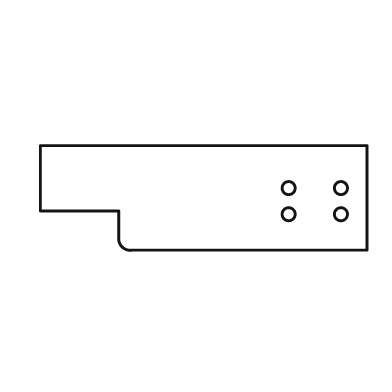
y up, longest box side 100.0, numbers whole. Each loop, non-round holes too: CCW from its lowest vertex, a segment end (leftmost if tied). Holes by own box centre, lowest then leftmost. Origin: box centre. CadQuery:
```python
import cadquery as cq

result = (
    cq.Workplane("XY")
    .moveTo(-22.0, -16.0)
    .lineTo(50.0, -16.0)
    .lineTo(50.0, 16.0)
    .lineTo(-50.0, 16.0)
    .lineTo(-50.0, -4.0)
    .lineTo(-26.0, -4.0)
    .lineTo(-26.0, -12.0)
    .threePointArc((-25.0, -15.0), (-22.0, -16.0))
    .close()
    .moveTo(26.0, -5.0)
    .circle(2.0)
    .moveTo(42.0, -5.0)
    .circle(2.0)
    .moveTo(26.0, 3.0)
    .circle(2.0)
    .moveTo(42.0, 3.0)
    .circle(2.0)
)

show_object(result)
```